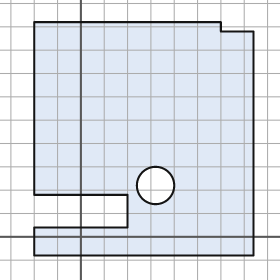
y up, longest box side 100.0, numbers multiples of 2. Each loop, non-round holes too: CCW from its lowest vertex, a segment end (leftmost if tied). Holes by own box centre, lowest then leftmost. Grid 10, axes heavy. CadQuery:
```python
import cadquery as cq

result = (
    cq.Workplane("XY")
    .moveTo(-20.0, -8.0)
    .lineTo(74.0, -8.0)
    .lineTo(74.0, 88.0)
    .lineTo(60.0, 88.0)
    .lineTo(60.0, 92.0)
    .lineTo(-20.0, 92.0)
    .lineTo(-20.0, 18.0)
    .lineTo(20.0, 18.0)
    .lineTo(20.0, 4.0)
    .lineTo(-20.0, 4.0)
    .close()
    .moveTo(32.0, 22.0)
    .circle(8.0)
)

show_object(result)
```